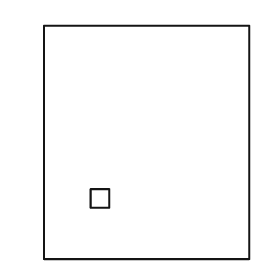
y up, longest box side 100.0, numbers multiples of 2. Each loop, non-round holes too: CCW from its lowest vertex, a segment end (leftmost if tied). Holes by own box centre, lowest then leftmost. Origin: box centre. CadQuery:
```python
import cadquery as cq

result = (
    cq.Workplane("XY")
    .moveTo(-44.0, -50.0)
    .lineTo(44.0, -50.0)
    .lineTo(44.0, 50.0)
    .lineTo(-44.0, 50.0)
    .close()
    .moveTo(-24.0, -28.0)
    .lineTo(-16.0, -28.0)
    .lineTo(-16.0, -20.0)
    .lineTo(-24.0, -20.0)
    .close()
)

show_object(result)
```